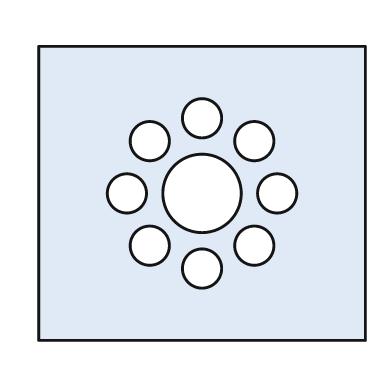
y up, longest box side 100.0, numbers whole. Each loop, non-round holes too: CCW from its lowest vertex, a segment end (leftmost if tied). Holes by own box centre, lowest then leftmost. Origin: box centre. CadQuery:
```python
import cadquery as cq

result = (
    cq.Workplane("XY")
    .moveTo(-50.0, -45.0)
    .lineTo(50.0, -45.0)
    .lineTo(50.0, 45.0)
    .lineTo(-50.0, 45.0)
    .close()
    .moveTo(0.0, -23.0)
    .circle(6.0)
    .moveTo(-16.0, -16.0)
    .circle(6.0)
    .moveTo(16.0, -16.0)
    .circle(6.0)
    .moveTo(-23.0, 0.0)
    .circle(6.0)
    .moveTo(0.0, 0.0)
    .circle(12.0)
    .moveTo(23.0, 0.0)
    .circle(6.0)
    .moveTo(-16.0, 16.0)
    .circle(6.0)
    .moveTo(16.0, 16.0)
    .circle(6.0)
    .moveTo(0.0, 23.0)
    .circle(6.0)
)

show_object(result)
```